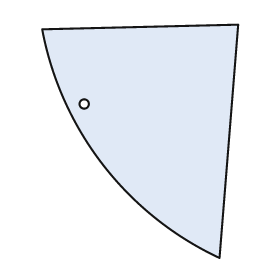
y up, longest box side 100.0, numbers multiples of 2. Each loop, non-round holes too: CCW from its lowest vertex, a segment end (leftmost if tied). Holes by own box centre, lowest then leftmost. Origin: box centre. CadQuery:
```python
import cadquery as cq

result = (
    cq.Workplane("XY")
    .moveTo(34.0, -50.0)
    .lineTo(42.0, 50.0)
    .lineTo(-42.0, 48.0)
    .threePointArc((-16.0, -10.0), (34.0, -50.0))
    .close()
    .moveTo(-24.0, 16.0)
    .circle(2.0)
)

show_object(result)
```